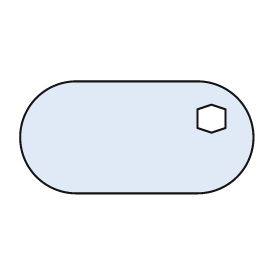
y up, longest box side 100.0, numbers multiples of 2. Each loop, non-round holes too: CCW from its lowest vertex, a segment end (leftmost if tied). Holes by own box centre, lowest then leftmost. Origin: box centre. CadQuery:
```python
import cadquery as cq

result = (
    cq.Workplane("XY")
    .moveTo(-26.0, -24.0)
    .lineTo(26.0, -24.0)
    .threePointArc((50.0, 0.0), (26.0, 24.0))
    .lineTo(-26.0, 24.0)
    .threePointArc((-50.0, 0.0), (-26.0, -24.0))
    .close()
    .moveTo(32.0, 2.0)
    .lineTo(38.0, 4.0)
    .lineTo(38.0, 12.0)
    .lineTo(32.0, 14.0)
    .lineTo(26.0, 12.0)
    .lineTo(26.0, 4.0)
    .close()
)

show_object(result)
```